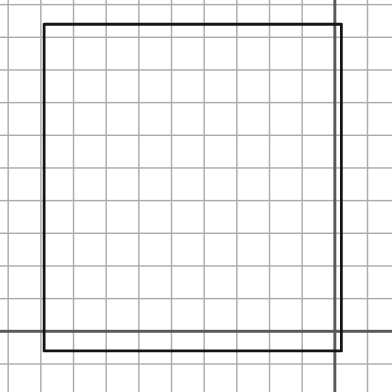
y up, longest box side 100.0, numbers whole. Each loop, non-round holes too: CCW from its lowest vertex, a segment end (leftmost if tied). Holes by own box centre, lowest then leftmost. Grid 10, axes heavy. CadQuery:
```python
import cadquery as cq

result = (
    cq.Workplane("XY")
    .moveTo(-89.0, -6.0)
    .lineTo(2.0, -6.0)
    .lineTo(2.0, 94.0)
    .lineTo(-89.0, 94.0)
    .close()
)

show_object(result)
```